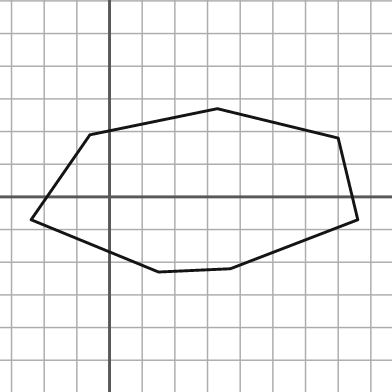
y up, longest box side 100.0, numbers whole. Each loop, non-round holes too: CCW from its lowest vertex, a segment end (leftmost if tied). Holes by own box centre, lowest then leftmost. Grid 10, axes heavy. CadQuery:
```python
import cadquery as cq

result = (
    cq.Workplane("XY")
    .moveTo(15.0, -23.0)
    .lineTo(37.0, -22.0)
    .lineTo(76.0, -7.0)
    .lineTo(70.0, 18.0)
    .lineTo(33.0, 27.0)
    .lineTo(-6.0, 19.0)
    .lineTo(-24.0, -7.0)
    .close()
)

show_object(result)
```